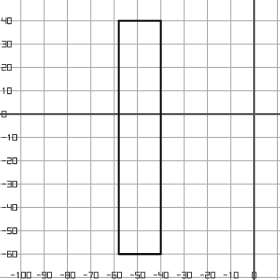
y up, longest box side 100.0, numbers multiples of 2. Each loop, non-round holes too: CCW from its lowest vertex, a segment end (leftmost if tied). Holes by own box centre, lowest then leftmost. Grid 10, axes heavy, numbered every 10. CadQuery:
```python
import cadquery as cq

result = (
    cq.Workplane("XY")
    .moveTo(-58.0, -60.0)
    .lineTo(-40.0, -60.0)
    .lineTo(-40.0, 40.0)
    .lineTo(-58.0, 40.0)
    .close()
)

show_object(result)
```